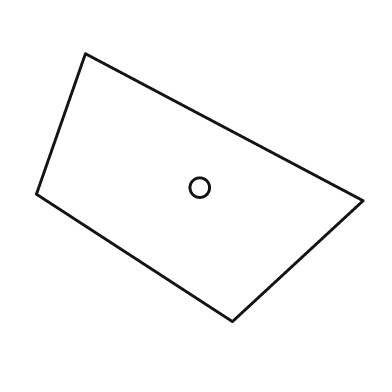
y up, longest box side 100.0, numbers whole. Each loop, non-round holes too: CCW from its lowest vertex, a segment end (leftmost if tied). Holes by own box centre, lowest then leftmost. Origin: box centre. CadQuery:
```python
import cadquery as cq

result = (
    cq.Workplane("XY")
    .moveTo(10.0, -41.0)
    .lineTo(50.0, -4.0)
    .lineTo(-35.0, 41.0)
    .lineTo(-50.0, -2.0)
    .close()
    .moveTo(0.0, 0.0)
    .circle(3.0)
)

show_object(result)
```